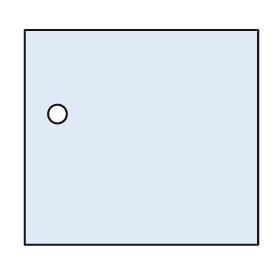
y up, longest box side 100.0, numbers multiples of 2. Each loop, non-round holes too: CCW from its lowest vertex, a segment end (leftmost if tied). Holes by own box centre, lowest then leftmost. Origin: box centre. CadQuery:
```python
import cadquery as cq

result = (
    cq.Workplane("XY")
    .moveTo(-50.0, -46.0)
    .lineTo(50.0, -46.0)
    .lineTo(50.0, 46.0)
    .lineTo(-50.0, 46.0)
    .close()
    .moveTo(-36.0, 10.0)
    .circle(4.0)
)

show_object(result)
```